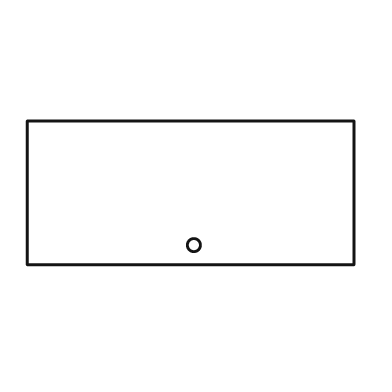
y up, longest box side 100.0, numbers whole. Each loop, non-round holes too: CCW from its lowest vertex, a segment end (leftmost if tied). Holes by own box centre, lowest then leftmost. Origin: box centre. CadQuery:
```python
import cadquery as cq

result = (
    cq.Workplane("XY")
    .moveTo(-50.0, -22.0)
    .lineTo(50.0, -22.0)
    .lineTo(50.0, 22.0)
    .lineTo(-50.0, 22.0)
    .close()
    .moveTo(1.0, -16.0)
    .circle(2.0)
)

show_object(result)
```